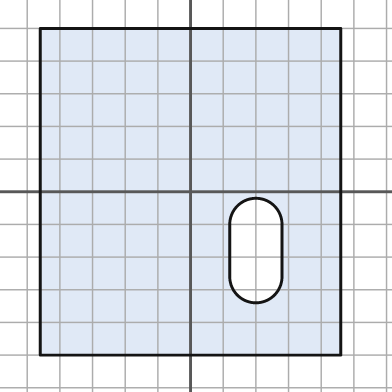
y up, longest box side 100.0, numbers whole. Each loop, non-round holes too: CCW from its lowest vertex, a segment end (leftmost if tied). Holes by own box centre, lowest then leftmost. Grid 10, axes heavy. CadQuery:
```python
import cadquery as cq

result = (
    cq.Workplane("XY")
    .moveTo(-46.0, -50.0)
    .lineTo(46.0, -50.0)
    .lineTo(46.0, 50.0)
    .lineTo(-46.0, 50.0)
    .close()
    .moveTo(12.0, -26.0)
    .threePointArc((20.0, -34.0), (28.0, -26.0))
    .lineTo(28.0, -10.0)
    .threePointArc((20.0, -2.0), (12.0, -10.0))
    .close()
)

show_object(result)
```